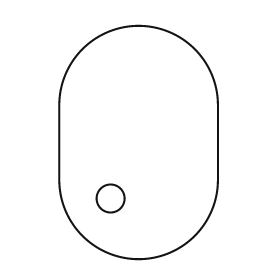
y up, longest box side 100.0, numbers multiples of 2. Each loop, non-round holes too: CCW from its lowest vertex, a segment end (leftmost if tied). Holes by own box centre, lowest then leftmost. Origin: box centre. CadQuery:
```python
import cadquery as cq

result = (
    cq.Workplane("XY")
    .moveTo(-34.0, -16.0)
    .threePointArc((0.0, -50.0), (34.0, -16.0))
    .lineTo(34.0, 16.0)
    .threePointArc((0.0, 50.0), (-34.0, 16.0))
    .close()
    .moveTo(-12.0, -24.0)
    .circle(6.0)
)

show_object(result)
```